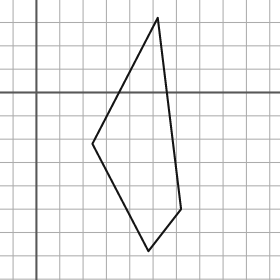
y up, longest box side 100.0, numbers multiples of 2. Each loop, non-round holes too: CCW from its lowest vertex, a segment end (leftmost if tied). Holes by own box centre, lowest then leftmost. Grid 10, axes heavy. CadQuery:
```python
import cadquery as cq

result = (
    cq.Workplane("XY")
    .moveTo(48.0, -68.0)
    .lineTo(62.0, -50.0)
    .lineTo(52.0, 32.0)
    .lineTo(24.0, -22.0)
    .close()
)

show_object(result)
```